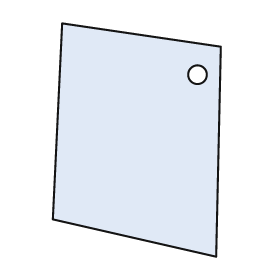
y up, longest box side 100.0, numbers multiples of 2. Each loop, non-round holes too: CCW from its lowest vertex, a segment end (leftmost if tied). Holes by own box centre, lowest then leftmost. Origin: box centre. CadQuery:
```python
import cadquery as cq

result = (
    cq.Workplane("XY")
    .moveTo(34.0, -50.0)
    .lineTo(36.0, 40.0)
    .lineTo(-32.0, 50.0)
    .lineTo(-36.0, -34.0)
    .close()
    .moveTo(26.0, 28.0)
    .circle(4.0)
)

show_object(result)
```